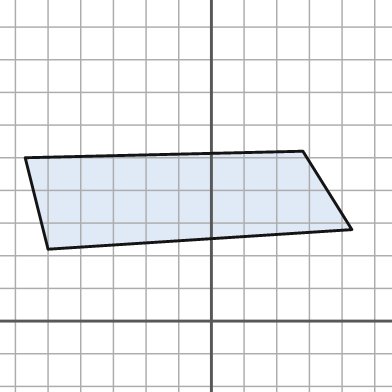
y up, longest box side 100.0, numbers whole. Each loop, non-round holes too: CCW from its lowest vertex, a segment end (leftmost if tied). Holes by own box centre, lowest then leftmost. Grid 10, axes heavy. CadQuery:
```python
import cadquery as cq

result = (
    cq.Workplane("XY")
    .moveTo(-50.0, 22.0)
    .lineTo(43.0, 28.0)
    .lineTo(28.0, 52.0)
    .lineTo(-57.0, 50.0)
    .close()
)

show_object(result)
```